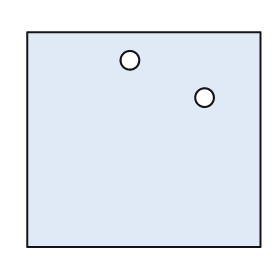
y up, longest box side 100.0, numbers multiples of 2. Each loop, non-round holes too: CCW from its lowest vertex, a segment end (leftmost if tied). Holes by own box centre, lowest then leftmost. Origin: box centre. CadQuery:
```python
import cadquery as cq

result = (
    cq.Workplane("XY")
    .moveTo(-50.0, -46.0)
    .lineTo(50.0, -46.0)
    .lineTo(50.0, 46.0)
    .lineTo(-50.0, 46.0)
    .close()
    .moveTo(26.0, 18.0)
    .circle(4.0)
    .moveTo(-6.0, 34.0)
    .circle(4.0)
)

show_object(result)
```